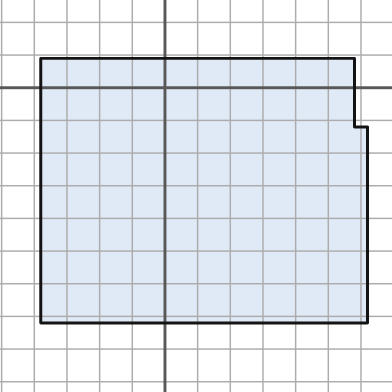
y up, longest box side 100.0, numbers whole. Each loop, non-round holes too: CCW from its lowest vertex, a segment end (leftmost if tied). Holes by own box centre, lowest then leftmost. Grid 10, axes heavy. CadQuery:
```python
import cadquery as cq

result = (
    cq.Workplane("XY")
    .moveTo(-38.0, -72.0)
    .lineTo(62.0, -72.0)
    .lineTo(62.0, -12.0)
    .lineTo(58.0, -12.0)
    .lineTo(58.0, 9.0)
    .lineTo(-38.0, 9.0)
    .close()
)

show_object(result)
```